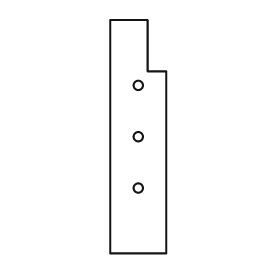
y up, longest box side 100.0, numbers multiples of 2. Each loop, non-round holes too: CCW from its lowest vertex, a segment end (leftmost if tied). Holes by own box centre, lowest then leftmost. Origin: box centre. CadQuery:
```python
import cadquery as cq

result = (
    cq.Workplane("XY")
    .moveTo(-12.0, -50.0)
    .lineTo(12.0, -50.0)
    .lineTo(12.0, 28.0)
    .lineTo(4.0, 28.0)
    .lineTo(4.0, 50.0)
    .lineTo(-12.0, 50.0)
    .close()
    .moveTo(0.0, -22.0)
    .circle(2.0)
    .moveTo(0.0, 0.0)
    .circle(2.0)
    .moveTo(0.0, 22.0)
    .circle(2.0)
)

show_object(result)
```